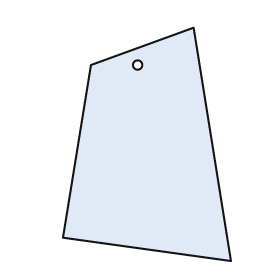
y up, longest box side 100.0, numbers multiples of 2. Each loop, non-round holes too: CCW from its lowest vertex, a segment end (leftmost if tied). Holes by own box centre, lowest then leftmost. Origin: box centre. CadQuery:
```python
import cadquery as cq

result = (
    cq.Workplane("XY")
    .moveTo(36.0, -50.0)
    .lineTo(20.0, 50.0)
    .lineTo(-24.0, 34.0)
    .lineTo(-36.0, -40.0)
    .close()
    .moveTo(-4.0, 34.0)
    .circle(2.0)
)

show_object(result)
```